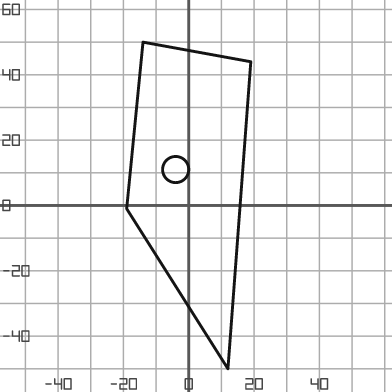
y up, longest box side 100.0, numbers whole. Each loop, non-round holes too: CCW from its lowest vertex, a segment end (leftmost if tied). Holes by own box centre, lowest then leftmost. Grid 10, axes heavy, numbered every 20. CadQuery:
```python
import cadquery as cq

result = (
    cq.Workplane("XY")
    .moveTo(12.0, -50.0)
    .lineTo(19.0, 44.0)
    .lineTo(-14.0, 50.0)
    .lineTo(-19.0, -1.0)
    .close()
    .moveTo(-4.0, 11.0)
    .circle(4.0)
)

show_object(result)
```